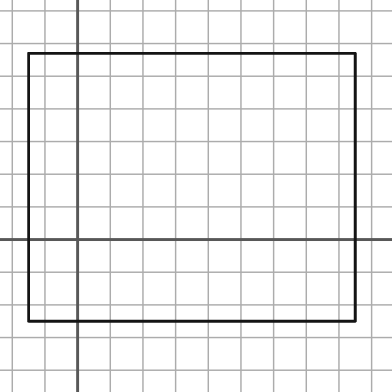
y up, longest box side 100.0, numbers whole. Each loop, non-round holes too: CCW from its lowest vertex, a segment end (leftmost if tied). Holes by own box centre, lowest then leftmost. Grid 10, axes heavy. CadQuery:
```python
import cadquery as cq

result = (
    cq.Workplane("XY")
    .moveTo(-15.0, -25.0)
    .lineTo(85.0, -25.0)
    .lineTo(85.0, 57.0)
    .lineTo(-15.0, 57.0)
    .close()
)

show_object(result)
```